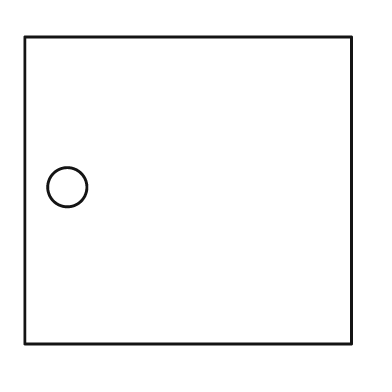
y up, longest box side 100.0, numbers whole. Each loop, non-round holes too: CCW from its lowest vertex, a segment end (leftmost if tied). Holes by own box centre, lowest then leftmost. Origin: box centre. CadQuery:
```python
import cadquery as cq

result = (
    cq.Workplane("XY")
    .moveTo(-50.0, -47.0)
    .lineTo(50.0, -47.0)
    .lineTo(50.0, 47.0)
    .lineTo(-50.0, 47.0)
    .close()
    .moveTo(-37.0, 1.0)
    .circle(6.0)
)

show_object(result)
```